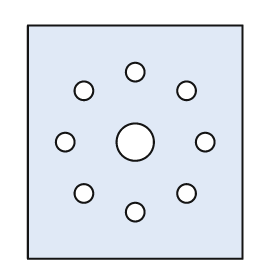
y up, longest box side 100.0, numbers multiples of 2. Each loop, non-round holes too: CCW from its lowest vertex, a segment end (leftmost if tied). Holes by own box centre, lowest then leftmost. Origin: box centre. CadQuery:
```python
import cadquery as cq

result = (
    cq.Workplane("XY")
    .moveTo(-46.0, -50.0)
    .lineTo(46.0, -50.0)
    .lineTo(46.0, 50.0)
    .lineTo(-46.0, 50.0)
    .close()
    .moveTo(0.0, -30.0)
    .circle(4.0)
    .moveTo(-22.0, -22.0)
    .circle(4.0)
    .moveTo(22.0, -22.0)
    .circle(4.0)
    .moveTo(-30.0, 0.0)
    .circle(4.0)
    .moveTo(0.0, 0.0)
    .circle(8.0)
    .moveTo(30.0, 0.0)
    .circle(4.0)
    .moveTo(-22.0, 22.0)
    .circle(4.0)
    .moveTo(22.0, 22.0)
    .circle(4.0)
    .moveTo(0.0, 30.0)
    .circle(4.0)
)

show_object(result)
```